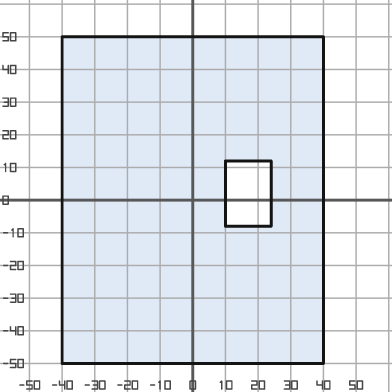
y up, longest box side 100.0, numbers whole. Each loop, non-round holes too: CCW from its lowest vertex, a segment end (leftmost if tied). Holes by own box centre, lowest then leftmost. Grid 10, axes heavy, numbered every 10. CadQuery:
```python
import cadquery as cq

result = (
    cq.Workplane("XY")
    .moveTo(-40.0, -50.0)
    .lineTo(40.0, -50.0)
    .lineTo(40.0, 50.0)
    .lineTo(-40.0, 50.0)
    .close()
    .moveTo(10.0, -8.0)
    .lineTo(24.0, -8.0)
    .lineTo(24.0, 12.0)
    .lineTo(10.0, 12.0)
    .close()
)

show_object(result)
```